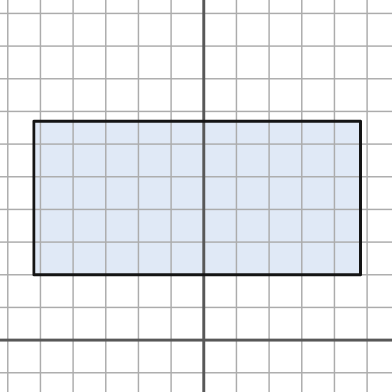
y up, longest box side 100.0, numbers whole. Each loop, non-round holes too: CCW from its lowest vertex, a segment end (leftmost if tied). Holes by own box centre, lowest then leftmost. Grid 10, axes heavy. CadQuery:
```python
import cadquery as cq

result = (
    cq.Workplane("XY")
    .moveTo(-52.0, 20.0)
    .lineTo(48.0, 20.0)
    .lineTo(48.0, 67.0)
    .lineTo(-52.0, 67.0)
    .close()
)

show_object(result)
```